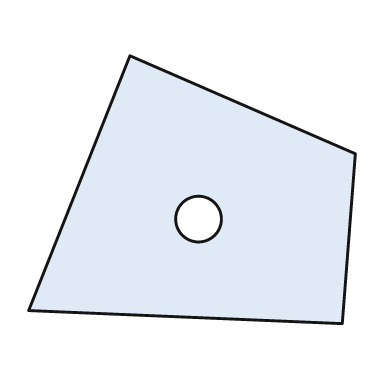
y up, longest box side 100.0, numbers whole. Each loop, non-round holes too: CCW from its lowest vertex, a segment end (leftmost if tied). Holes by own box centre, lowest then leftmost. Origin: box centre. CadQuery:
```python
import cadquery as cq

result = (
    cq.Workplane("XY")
    .moveTo(46.0, -41.0)
    .lineTo(50.0, 11.0)
    .lineTo(-19.0, 41.0)
    .lineTo(-50.0, -37.0)
    .close()
    .moveTo(2.0, -9.0)
    .circle(7.0)
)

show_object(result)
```